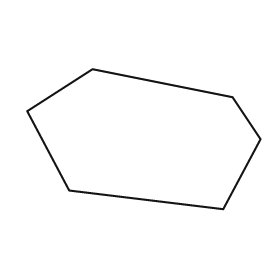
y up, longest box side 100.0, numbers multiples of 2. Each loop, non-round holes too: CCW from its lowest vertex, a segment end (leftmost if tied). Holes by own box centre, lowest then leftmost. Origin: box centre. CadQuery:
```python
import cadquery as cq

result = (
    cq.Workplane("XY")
    .moveTo(34.0, -30.0)
    .lineTo(50.0, 0.0)
    .lineTo(38.0, 18.0)
    .lineTo(-22.0, 30.0)
    .lineTo(-50.0, 12.0)
    .lineTo(-32.0, -22.0)
    .close()
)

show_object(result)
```